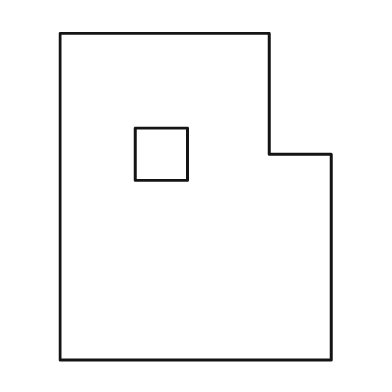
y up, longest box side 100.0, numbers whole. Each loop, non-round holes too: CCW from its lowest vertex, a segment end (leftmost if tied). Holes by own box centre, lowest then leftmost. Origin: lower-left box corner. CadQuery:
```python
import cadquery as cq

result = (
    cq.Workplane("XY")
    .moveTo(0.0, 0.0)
    .lineTo(83.0, 0.0)
    .lineTo(83.0, 63.0)
    .lineTo(64.0, 63.0)
    .lineTo(64.0, 100.0)
    .lineTo(0.0, 100.0)
    .close()
    .moveTo(23.0, 55.0)
    .lineTo(39.0, 55.0)
    .lineTo(39.0, 71.0)
    .lineTo(23.0, 71.0)
    .close()
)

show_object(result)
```